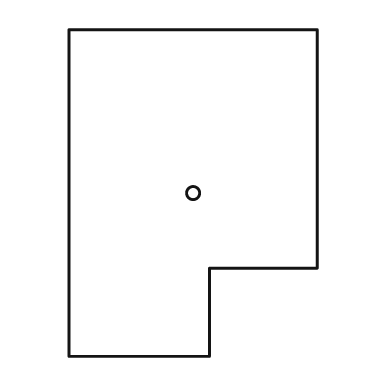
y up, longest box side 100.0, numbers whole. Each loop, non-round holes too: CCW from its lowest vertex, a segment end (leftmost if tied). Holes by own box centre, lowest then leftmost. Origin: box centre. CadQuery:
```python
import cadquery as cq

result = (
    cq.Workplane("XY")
    .moveTo(-38.0, -50.0)
    .lineTo(5.0, -50.0)
    .lineTo(5.0, -23.0)
    .lineTo(38.0, -23.0)
    .lineTo(38.0, 50.0)
    .lineTo(-38.0, 50.0)
    .close()
    .moveTo(0.0, 0.0)
    .circle(2.0)
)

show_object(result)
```